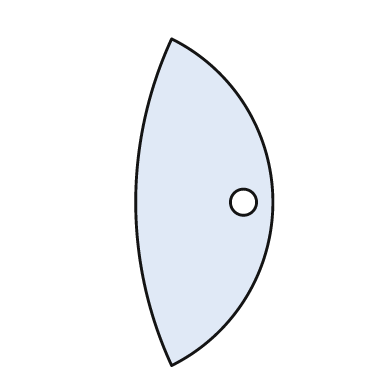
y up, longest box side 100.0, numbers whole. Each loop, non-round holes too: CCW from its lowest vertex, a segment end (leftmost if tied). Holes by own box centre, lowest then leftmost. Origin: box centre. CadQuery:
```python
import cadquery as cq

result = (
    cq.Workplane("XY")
    .moveTo(-10.0, -50.0)
    .threePointArc((21.0, 0.0), (-10.0, 50.0))
    .threePointArc((-21.0, 0.0), (-10.0, -50.0))
    .close()
    .moveTo(12.0, 0.0)
    .circle(4.0)
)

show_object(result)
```